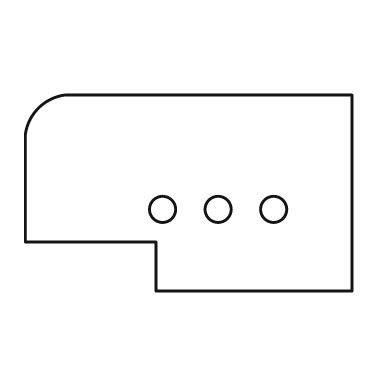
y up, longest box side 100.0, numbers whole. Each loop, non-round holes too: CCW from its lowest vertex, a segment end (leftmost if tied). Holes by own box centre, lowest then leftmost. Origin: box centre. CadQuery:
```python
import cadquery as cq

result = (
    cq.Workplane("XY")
    .moveTo(-10.0, -30.0)
    .lineTo(50.0, -30.0)
    .lineTo(50.0, 30.0)
    .lineTo(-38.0, 30.0)
    .threePointArc((-46.0, 26.0), (-50.0, 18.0))
    .lineTo(-50.0, -15.0)
    .lineTo(-10.0, -15.0)
    .close()
    .moveTo(-8.0, -5.0)
    .circle(4.0)
    .moveTo(9.0, -5.0)
    .circle(4.0)
    .moveTo(26.0, -5.0)
    .circle(4.0)
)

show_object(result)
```